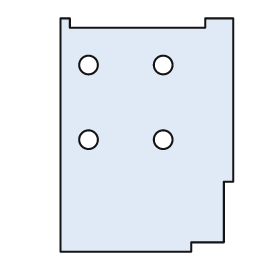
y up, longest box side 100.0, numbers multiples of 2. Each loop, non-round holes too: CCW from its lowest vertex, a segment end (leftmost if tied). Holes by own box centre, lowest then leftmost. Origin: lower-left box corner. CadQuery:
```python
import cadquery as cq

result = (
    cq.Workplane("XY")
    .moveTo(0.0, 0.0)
    .lineTo(56.0, 0.0)
    .lineTo(56.0, 4.0)
    .lineTo(70.0, 4.0)
    .lineTo(70.0, 30.0)
    .lineTo(74.0, 30.0)
    .lineTo(74.0, 100.0)
    .lineTo(62.0, 100.0)
    .lineTo(62.0, 96.0)
    .lineTo(4.0, 96.0)
    .lineTo(4.0, 100.0)
    .lineTo(0.0, 100.0)
    .close()
    .moveTo(12.0, 48.0)
    .circle(4.0)
    .moveTo(44.0, 48.0)
    .circle(4.0)
    .moveTo(12.0, 80.0)
    .circle(4.0)
    .moveTo(44.0, 80.0)
    .circle(4.0)
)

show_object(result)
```